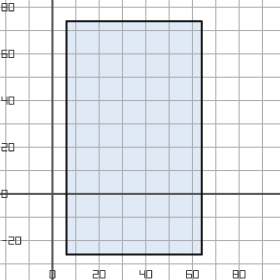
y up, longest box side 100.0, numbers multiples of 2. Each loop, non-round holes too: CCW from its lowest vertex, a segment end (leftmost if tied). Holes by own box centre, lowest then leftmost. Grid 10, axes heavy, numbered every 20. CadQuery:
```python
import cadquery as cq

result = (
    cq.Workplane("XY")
    .moveTo(6.0, -26.0)
    .lineTo(64.0, -26.0)
    .lineTo(64.0, 74.0)
    .lineTo(6.0, 74.0)
    .close()
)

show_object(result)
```